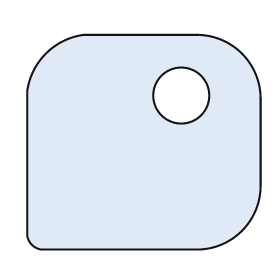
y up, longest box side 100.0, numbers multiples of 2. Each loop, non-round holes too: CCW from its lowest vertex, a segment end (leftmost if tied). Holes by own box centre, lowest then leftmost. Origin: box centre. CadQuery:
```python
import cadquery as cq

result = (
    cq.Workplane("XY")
    .moveTo(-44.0, -46.0)
    .lineTo(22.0, -46.0)
    .threePointArc((42.0, -38.0), (50.0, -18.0))
    .lineTo(50.0, 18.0)
    .threePointArc((42.0, 38.0), (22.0, 46.0))
    .lineTo(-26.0, 46.0)
    .threePointArc((-42.0, 38.0), (-50.0, 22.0))
    .lineTo(-50.0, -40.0)
    .threePointArc((-48.0, -44.0), (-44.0, -46.0))
    .close()
    .moveTo(16.0, 20.0)
    .circle(12.0)
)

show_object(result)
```